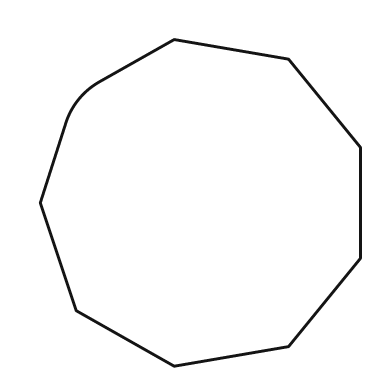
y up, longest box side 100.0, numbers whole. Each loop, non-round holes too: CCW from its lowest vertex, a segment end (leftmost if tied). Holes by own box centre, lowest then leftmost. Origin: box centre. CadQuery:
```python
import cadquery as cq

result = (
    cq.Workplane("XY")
    .moveTo(-8.0, -50.0)
    .lineTo(27.0, -44.0)
    .lineTo(49.0, -17.0)
    .lineTo(49.0, 17.0)
    .lineTo(27.0, 44.0)
    .lineTo(-8.0, 50.0)
    .lineTo(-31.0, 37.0)
    .threePointArc((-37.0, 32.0), (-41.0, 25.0))
    .lineTo(-49.0, 0.0)
    .lineTo(-38.0, -33.0)
    .close()
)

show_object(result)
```